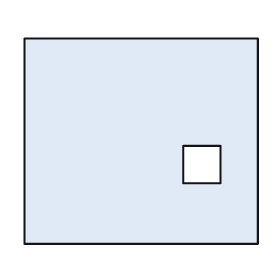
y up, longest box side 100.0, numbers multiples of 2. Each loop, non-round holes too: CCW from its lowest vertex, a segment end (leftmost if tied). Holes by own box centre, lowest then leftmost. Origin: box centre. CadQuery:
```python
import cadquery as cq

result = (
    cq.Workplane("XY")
    .moveTo(-50.0, -44.0)
    .lineTo(50.0, -44.0)
    .lineTo(50.0, 44.0)
    .lineTo(-50.0, 44.0)
    .close()
    .moveTo(18.0, -18.0)
    .lineTo(34.0, -18.0)
    .lineTo(34.0, -2.0)
    .lineTo(18.0, -2.0)
    .close()
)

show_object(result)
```